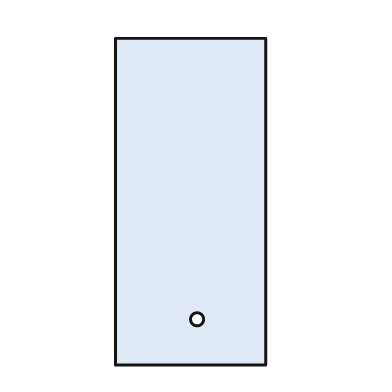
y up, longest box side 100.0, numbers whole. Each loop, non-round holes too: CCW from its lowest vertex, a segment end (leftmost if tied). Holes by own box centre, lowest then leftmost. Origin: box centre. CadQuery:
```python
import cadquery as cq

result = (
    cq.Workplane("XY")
    .moveTo(-23.0, -50.0)
    .lineTo(23.0, -50.0)
    .lineTo(23.0, 50.0)
    .lineTo(-23.0, 50.0)
    .close()
    .moveTo(2.0, -36.0)
    .circle(2.0)
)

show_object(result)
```